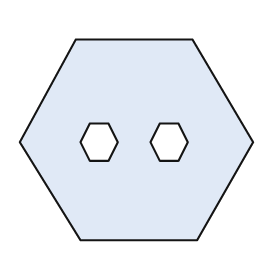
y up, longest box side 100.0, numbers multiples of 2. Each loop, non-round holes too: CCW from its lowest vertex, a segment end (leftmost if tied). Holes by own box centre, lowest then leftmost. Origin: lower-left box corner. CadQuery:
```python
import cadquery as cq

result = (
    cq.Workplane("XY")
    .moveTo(26.0, 0.0)
    .lineTo(76.0, 0.0)
    .lineTo(100.0, 42.0)
    .lineTo(74.0, 86.0)
    .lineTo(24.0, 86.0)
    .lineTo(0.0, 42.0)
    .close()
    .moveTo(30.0, 34.0)
    .lineTo(38.0, 34.0)
    .lineTo(42.0, 42.0)
    .lineTo(38.0, 50.0)
    .lineTo(30.0, 50.0)
    .lineTo(26.0, 42.0)
    .close()
    .moveTo(60.0, 34.0)
    .lineTo(68.0, 34.0)
    .lineTo(72.0, 42.0)
    .lineTo(68.0, 50.0)
    .lineTo(60.0, 50.0)
    .lineTo(56.0, 42.0)
    .close()
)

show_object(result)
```